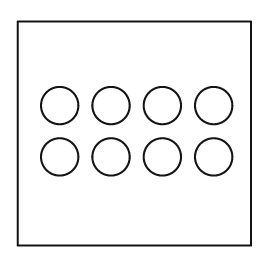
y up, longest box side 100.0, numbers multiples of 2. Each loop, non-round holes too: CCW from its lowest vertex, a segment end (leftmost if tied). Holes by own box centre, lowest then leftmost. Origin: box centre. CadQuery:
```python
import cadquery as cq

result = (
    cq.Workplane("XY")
    .moveTo(-50.0, -48.0)
    .lineTo(50.0, -48.0)
    .lineTo(50.0, 48.0)
    .lineTo(-50.0, 48.0)
    .close()
    .moveTo(-32.0, -10.0)
    .circle(8.0)
    .moveTo(-10.0, -10.0)
    .circle(8.0)
    .moveTo(12.0, -10.0)
    .circle(8.0)
    .moveTo(34.0, -10.0)
    .circle(8.0)
    .moveTo(-32.0, 12.0)
    .circle(8.0)
    .moveTo(-10.0, 12.0)
    .circle(8.0)
    .moveTo(12.0, 12.0)
    .circle(8.0)
    .moveTo(34.0, 12.0)
    .circle(8.0)
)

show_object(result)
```